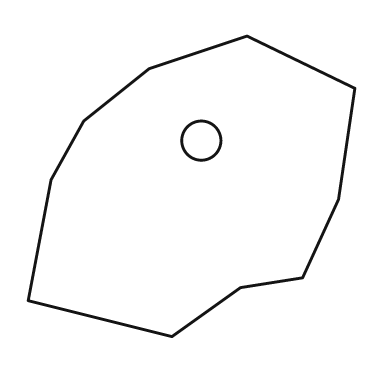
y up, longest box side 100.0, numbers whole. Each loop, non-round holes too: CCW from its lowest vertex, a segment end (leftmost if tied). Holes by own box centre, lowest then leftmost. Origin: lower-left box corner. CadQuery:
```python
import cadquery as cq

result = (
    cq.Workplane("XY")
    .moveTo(44.0, 0.0)
    .lineTo(65.0, 15.0)
    .lineTo(84.0, 18.0)
    .lineTo(95.0, 42.0)
    .lineTo(100.0, 76.0)
    .lineTo(67.0, 92.0)
    .lineTo(37.0, 82.0)
    .lineTo(17.0, 66.0)
    .lineTo(7.0, 48.0)
    .lineTo(0.0, 11.0)
    .close()
    .moveTo(53.0, 60.0)
    .circle(6.0)
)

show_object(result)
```